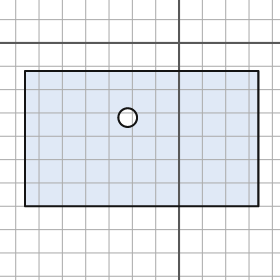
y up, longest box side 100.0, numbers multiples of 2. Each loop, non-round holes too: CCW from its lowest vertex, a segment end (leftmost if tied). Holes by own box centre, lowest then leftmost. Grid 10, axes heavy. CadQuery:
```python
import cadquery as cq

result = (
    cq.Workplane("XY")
    .moveTo(-66.0, -70.0)
    .lineTo(34.0, -70.0)
    .lineTo(34.0, -12.0)
    .lineTo(-66.0, -12.0)
    .close()
    .moveTo(-22.0, -32.0)
    .circle(4.0)
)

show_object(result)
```